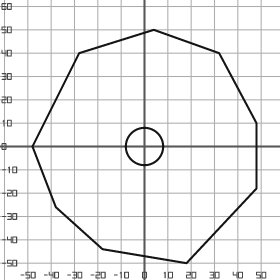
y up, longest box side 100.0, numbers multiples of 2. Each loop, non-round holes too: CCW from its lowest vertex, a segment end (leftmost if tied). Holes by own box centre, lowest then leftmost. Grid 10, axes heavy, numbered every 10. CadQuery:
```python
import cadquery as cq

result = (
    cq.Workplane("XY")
    .moveTo(18.0, -50.0)
    .lineTo(48.0, -18.0)
    .lineTo(48.0, 10.0)
    .lineTo(32.0, 40.0)
    .lineTo(4.0, 50.0)
    .lineTo(-28.0, 40.0)
    .lineTo(-48.0, 0.0)
    .lineTo(-38.0, -26.0)
    .lineTo(-18.0, -44.0)
    .close()
    .moveTo(0.0, 0.0)
    .circle(8.0)
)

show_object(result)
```